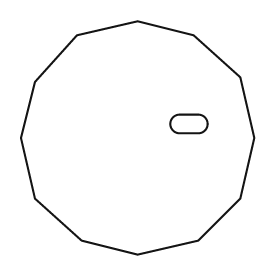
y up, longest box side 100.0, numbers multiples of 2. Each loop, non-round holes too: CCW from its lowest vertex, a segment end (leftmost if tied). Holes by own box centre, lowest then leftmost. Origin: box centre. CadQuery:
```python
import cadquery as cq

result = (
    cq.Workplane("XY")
    .moveTo(0.0, -50.0)
    .lineTo(26.0, -44.0)
    .lineTo(44.0, -26.0)
    .lineTo(50.0, 0.0)
    .lineTo(44.0, 26.0)
    .lineTo(24.0, 44.0)
    .lineTo(0.0, 50.0)
    .lineTo(-26.0, 44.0)
    .lineTo(-44.0, 24.0)
    .lineTo(-50.0, 0.0)
    .lineTo(-44.0, -26.0)
    .lineTo(-24.0, -44.0)
    .close()
    .moveTo(18.0, 2.0)
    .lineTo(26.0, 2.0)
    .threePointArc((30.0, 6.0), (26.0, 10.0))
    .lineTo(18.0, 10.0)
    .threePointArc((14.0, 6.0), (18.0, 2.0))
    .close()
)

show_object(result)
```